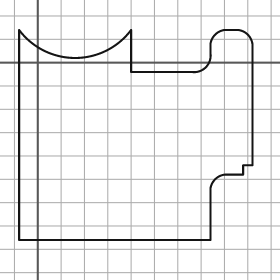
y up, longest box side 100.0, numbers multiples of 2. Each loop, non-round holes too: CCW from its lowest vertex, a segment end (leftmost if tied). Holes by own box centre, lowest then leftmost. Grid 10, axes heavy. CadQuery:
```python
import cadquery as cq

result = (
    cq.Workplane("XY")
    .moveTo(-8.0, -76.0)
    .lineTo(74.0, -76.0)
    .lineTo(74.0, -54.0)
    .threePointArc((76.0, -50.0), (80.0, -48.0))
    .lineTo(88.0, -48.0)
    .lineTo(88.0, -44.0)
    .lineTo(92.0, -44.0)
    .lineTo(92.0, 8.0)
    .threePointArc((90.0, 12.0), (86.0, 14.0))
    .lineTo(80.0, 14.0)
    .threePointArc((76.0, 12.0), (74.0, 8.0))
    .lineTo(74.0, 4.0)
    .threePointArc((72.0, -2.0), (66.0, -4.0))
    .lineTo(40.0, -4.0)
    .lineTo(40.0, 14.0)
    .threePointArc((16.0, 2.0), (-8.0, 14.0))
    .close()
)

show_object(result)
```